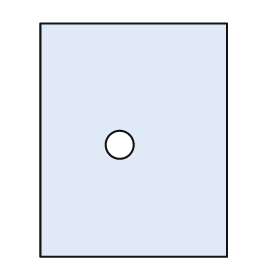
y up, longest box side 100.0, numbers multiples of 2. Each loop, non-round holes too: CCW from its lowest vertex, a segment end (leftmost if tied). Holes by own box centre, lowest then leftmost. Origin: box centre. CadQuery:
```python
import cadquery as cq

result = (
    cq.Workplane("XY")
    .moveTo(-40.0, -50.0)
    .lineTo(40.0, -50.0)
    .lineTo(40.0, 50.0)
    .lineTo(-40.0, 50.0)
    .close()
    .moveTo(-6.0, -2.0)
    .circle(6.0)
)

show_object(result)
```